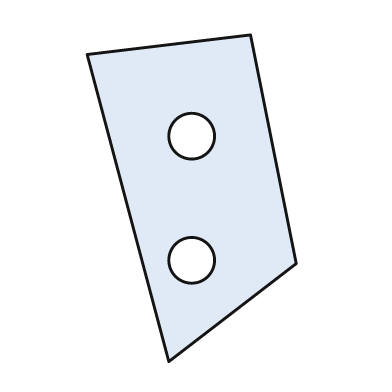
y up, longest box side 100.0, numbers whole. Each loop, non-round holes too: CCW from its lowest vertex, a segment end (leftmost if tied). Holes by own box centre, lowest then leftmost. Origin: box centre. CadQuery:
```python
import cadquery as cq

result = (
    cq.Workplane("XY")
    .moveTo(-7.0, -50.0)
    .lineTo(32.0, -20.0)
    .lineTo(18.0, 50.0)
    .lineTo(-32.0, 44.0)
    .close()
    .moveTo(0.0, -19.0)
    .circle(7.0)
    .moveTo(0.0, 19.0)
    .circle(7.0)
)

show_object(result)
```